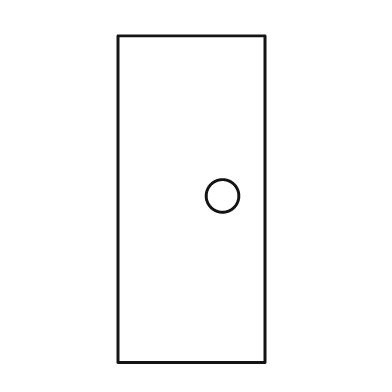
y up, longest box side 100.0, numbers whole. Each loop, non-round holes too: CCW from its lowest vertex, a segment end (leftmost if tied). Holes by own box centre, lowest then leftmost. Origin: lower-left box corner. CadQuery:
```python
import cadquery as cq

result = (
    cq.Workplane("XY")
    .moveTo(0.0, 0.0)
    .lineTo(45.0, 0.0)
    .lineTo(45.0, 100.0)
    .lineTo(0.0, 100.0)
    .close()
    .moveTo(32.0, 51.0)
    .circle(5.0)
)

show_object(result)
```